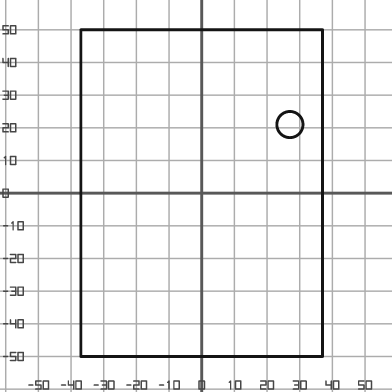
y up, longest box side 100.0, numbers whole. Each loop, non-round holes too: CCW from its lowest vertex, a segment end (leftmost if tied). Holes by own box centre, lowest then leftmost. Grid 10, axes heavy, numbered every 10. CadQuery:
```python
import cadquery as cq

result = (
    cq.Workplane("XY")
    .moveTo(-37.0, -50.0)
    .lineTo(37.0, -50.0)
    .lineTo(37.0, 50.0)
    .lineTo(-37.0, 50.0)
    .close()
    .moveTo(27.0, 21.0)
    .circle(4.0)
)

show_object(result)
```